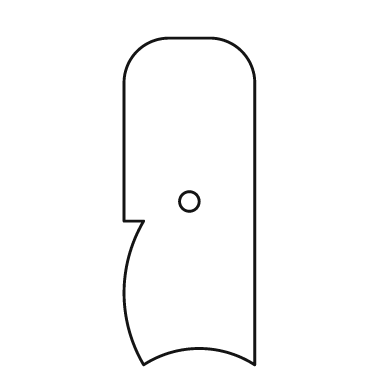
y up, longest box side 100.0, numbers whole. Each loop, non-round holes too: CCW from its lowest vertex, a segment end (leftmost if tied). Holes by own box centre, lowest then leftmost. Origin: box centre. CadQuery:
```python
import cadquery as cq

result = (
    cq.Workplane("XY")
    .moveTo(-14.0, -50.0)
    .threePointArc((3.0, -45.0), (20.0, -50.0))
    .lineTo(20.0, 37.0)
    .threePointArc((16.0, 46.0), (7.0, 50.0))
    .lineTo(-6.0, 50.0)
    .threePointArc((-16.0, 46.0), (-20.0, 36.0))
    .lineTo(-20.0, -6.0)
    .lineTo(-14.0, -6.0)
    .threePointArc((-20.0, -28.0), (-14.0, -50.0))
    .close()
    .moveTo(0.0, 0.0)
    .circle(3.0)
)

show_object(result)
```